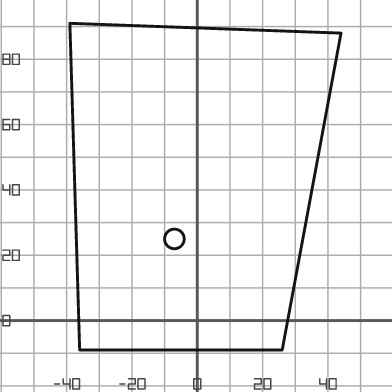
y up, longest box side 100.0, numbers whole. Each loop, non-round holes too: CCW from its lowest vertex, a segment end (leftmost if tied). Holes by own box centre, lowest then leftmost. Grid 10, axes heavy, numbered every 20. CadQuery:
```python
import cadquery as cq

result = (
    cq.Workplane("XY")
    .moveTo(-36.0, -9.0)
    .lineTo(26.0, -9.0)
    .lineTo(44.0, 88.0)
    .lineTo(-39.0, 91.0)
    .close()
    .moveTo(-7.0, 25.0)
    .circle(3.0)
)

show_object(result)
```